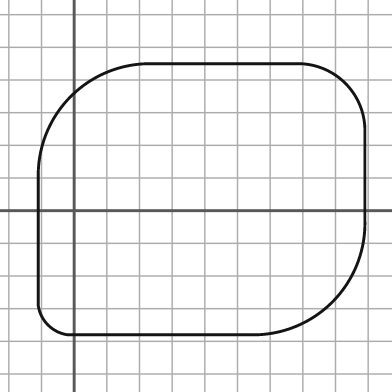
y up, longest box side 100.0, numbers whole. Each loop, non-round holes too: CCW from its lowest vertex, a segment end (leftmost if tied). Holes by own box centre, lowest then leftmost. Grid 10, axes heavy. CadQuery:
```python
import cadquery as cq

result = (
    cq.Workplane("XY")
    .moveTo(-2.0, -38.0)
    .lineTo(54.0, -38.0)
    .threePointArc((79.0, -28.0), (89.0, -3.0))
    .lineTo(89.0, 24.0)
    .threePointArc((83.0, 39.0), (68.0, 45.0))
    .lineTo(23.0, 45.0)
    .threePointArc((-1.0, 35.0), (-11.0, 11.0))
    .lineTo(-11.0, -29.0)
    .threePointArc((-8.0, -35.0), (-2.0, -38.0))
    .close()
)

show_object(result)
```